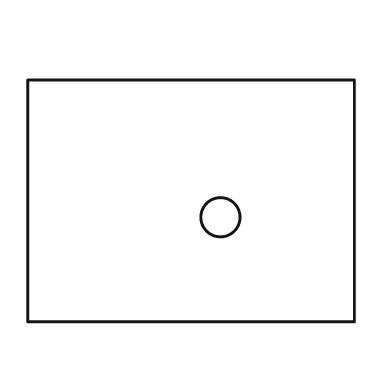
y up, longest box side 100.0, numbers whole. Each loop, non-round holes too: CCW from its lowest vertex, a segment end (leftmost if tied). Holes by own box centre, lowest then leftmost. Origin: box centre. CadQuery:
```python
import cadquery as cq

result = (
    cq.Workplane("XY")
    .moveTo(-50.0, -37.0)
    .lineTo(50.0, -37.0)
    .lineTo(50.0, 37.0)
    .lineTo(-50.0, 37.0)
    .close()
    .moveTo(9.0, -5.0)
    .circle(6.0)
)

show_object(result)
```